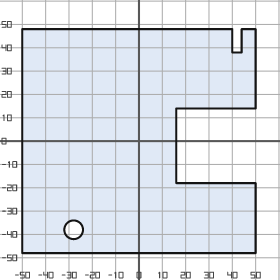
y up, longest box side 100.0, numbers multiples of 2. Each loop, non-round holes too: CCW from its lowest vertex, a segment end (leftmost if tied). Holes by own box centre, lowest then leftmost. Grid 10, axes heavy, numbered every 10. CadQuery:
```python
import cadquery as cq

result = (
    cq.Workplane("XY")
    .moveTo(-50.0, -48.0)
    .lineTo(50.0, -48.0)
    .lineTo(50.0, -18.0)
    .lineTo(16.0, -18.0)
    .lineTo(16.0, 14.0)
    .lineTo(50.0, 14.0)
    .lineTo(50.0, 48.0)
    .lineTo(44.0, 48.0)
    .lineTo(44.0, 38.0)
    .lineTo(40.0, 38.0)
    .lineTo(40.0, 48.0)
    .lineTo(-50.0, 48.0)
    .close()
    .moveTo(-28.0, -38.0)
    .circle(4.0)
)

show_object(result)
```